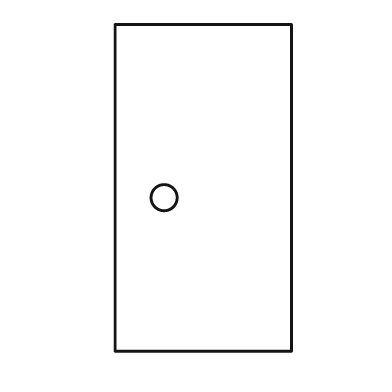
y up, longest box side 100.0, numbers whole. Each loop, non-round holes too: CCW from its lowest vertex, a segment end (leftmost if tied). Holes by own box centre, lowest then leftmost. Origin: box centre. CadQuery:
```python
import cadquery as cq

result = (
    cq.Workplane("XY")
    .moveTo(-27.0, -50.0)
    .lineTo(27.0, -50.0)
    .lineTo(27.0, 50.0)
    .lineTo(-27.0, 50.0)
    .close()
    .moveTo(-12.0, -3.0)
    .circle(4.0)
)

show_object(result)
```